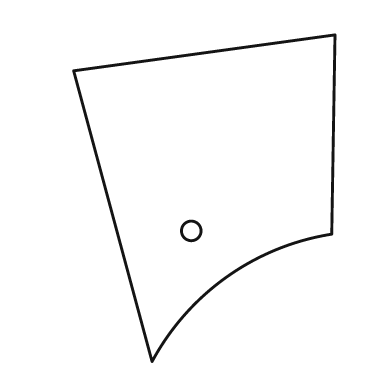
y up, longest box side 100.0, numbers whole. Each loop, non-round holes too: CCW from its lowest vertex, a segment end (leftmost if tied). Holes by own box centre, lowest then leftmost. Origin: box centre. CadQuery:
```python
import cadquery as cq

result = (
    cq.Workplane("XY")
    .moveTo(-16.0, -50.0)
    .threePointArc((7.0, -24.0), (39.0, -11.0))
    .lineTo(40.0, 50.0)
    .lineTo(-40.0, 39.0)
    .close()
    .moveTo(-4.0, -10.0)
    .circle(3.0)
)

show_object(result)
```